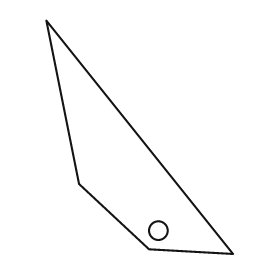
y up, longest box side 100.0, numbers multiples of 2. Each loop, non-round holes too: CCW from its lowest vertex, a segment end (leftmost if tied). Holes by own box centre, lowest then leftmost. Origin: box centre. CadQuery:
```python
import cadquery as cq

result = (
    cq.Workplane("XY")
    .moveTo(40.0, -50.0)
    .lineTo(-40.0, 50.0)
    .lineTo(-26.0, -20.0)
    .lineTo(4.0, -48.0)
    .close()
    .moveTo(8.0, -40.0)
    .circle(4.0)
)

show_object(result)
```